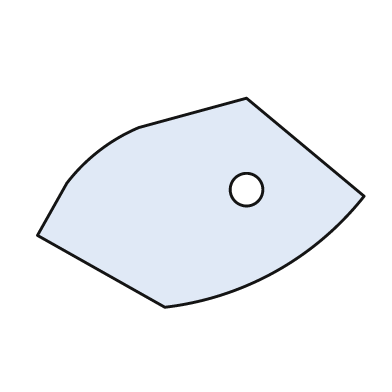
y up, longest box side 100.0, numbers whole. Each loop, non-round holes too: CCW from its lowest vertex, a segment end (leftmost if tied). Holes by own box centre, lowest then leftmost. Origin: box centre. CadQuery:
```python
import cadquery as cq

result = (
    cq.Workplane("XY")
    .moveTo(-11.0, -32.0)
    .threePointArc((23.0, -21.0), (50.0, 2.0))
    .lineTo(14.0, 32.0)
    .lineTo(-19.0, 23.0)
    .threePointArc((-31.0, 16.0), (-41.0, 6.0))
    .lineTo(-50.0, -10.0)
    .close()
    .moveTo(14.0, 4.0)
    .circle(5.0)
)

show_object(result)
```